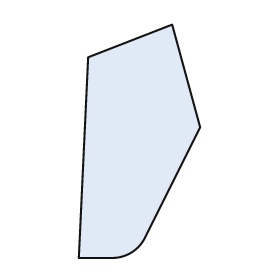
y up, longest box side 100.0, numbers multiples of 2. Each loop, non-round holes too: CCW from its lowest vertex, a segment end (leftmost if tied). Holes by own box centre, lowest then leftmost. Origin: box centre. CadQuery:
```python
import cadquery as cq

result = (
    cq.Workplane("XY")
    .moveTo(-26.0, -50.0)
    .lineTo(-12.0, -50.0)
    .threePointArc((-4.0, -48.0), (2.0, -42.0))
    .lineTo(26.0, 6.0)
    .lineTo(14.0, 50.0)
    .lineTo(-22.0, 36.0)
    .close()
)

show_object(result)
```